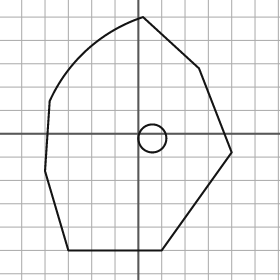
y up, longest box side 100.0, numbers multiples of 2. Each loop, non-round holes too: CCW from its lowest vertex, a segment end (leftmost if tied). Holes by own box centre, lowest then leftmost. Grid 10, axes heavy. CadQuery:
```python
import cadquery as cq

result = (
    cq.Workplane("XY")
    .moveTo(-30.0, -50.0)
    .lineTo(10.0, -50.0)
    .lineTo(40.0, -8.0)
    .lineTo(26.0, 28.0)
    .lineTo(2.0, 50.0)
    .threePointArc((-22.0, 36.0), (-38.0, 14.0))
    .lineTo(-40.0, -16.0)
    .close()
    .moveTo(6.0, -2.0)
    .circle(6.0)
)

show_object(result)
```